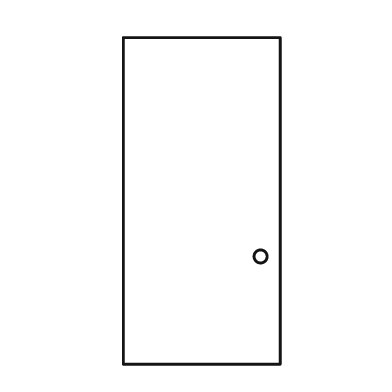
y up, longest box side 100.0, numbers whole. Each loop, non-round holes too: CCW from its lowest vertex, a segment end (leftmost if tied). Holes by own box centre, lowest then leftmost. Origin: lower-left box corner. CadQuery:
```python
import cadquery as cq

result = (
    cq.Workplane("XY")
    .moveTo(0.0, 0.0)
    .lineTo(48.0, 0.0)
    .lineTo(48.0, 100.0)
    .lineTo(0.0, 100.0)
    .close()
    .moveTo(42.0, 33.0)
    .circle(2.0)
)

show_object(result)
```